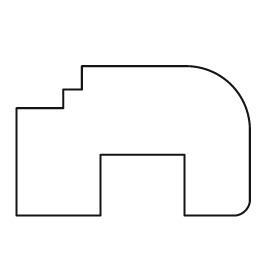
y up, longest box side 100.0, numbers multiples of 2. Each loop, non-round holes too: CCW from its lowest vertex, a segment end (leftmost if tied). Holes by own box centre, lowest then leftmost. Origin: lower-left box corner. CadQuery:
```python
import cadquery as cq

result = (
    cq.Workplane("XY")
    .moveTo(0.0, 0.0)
    .lineTo(36.0, 0.0)
    .lineTo(36.0, 26.0)
    .lineTo(72.0, 26.0)
    .lineTo(72.0, 0.0)
    .lineTo(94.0, 0.0)
    .threePointArc((98.0, 2.0), (100.0, 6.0))
    .lineTo(100.0, 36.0)
    .threePointArc((92.0, 56.0), (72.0, 64.0))
    .lineTo(28.0, 64.0)
    .lineTo(28.0, 54.0)
    .lineTo(20.0, 54.0)
    .lineTo(20.0, 46.0)
    .lineTo(0.0, 46.0)
    .close()
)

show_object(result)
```